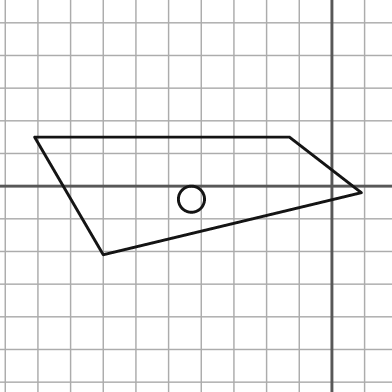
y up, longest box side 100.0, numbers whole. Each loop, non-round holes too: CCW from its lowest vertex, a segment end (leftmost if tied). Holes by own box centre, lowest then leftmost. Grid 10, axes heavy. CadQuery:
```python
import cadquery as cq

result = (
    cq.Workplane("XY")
    .moveTo(-70.0, -21.0)
    .lineTo(9.0, -2.0)
    .lineTo(-13.0, 15.0)
    .lineTo(-91.0, 15.0)
    .close()
    .moveTo(-43.0, -4.0)
    .circle(4.0)
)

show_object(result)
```